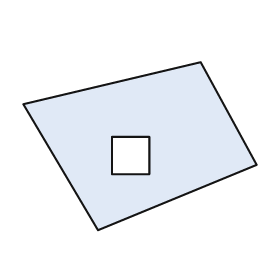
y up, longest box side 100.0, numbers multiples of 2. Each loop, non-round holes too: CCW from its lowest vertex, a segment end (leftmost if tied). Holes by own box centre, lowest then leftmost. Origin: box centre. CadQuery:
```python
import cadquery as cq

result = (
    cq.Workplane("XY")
    .moveTo(-18.0, -36.0)
    .lineTo(50.0, -8.0)
    .lineTo(26.0, 36.0)
    .lineTo(-50.0, 18.0)
    .close()
    .moveTo(-12.0, -12.0)
    .lineTo(4.0, -12.0)
    .lineTo(4.0, 4.0)
    .lineTo(-12.0, 4.0)
    .close()
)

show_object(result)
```